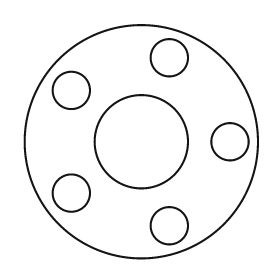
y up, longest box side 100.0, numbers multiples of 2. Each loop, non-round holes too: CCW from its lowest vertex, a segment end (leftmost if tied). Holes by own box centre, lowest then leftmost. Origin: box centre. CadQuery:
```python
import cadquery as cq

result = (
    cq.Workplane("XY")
    .moveTo(0.0, 0.0)
    .circle(50.0)
    .moveTo(12.0, -36.0)
    .circle(8.0)
    .moveTo(-30.0, -22.0)
    .circle(8.0)
    .moveTo(0.0, 0.0)
    .circle(20.0)
    .moveTo(38.0, 0.0)
    .circle(8.0)
    .moveTo(-30.0, 22.0)
    .circle(8.0)
    .moveTo(12.0, 36.0)
    .circle(8.0)
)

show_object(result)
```